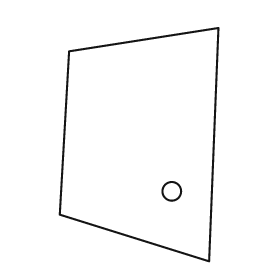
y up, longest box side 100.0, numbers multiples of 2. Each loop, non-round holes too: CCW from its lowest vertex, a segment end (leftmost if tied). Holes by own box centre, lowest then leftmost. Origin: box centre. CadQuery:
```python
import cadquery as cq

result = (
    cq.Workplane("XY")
    .moveTo(30.0, -50.0)
    .lineTo(34.0, 50.0)
    .lineTo(-30.0, 40.0)
    .lineTo(-34.0, -30.0)
    .close()
    .moveTo(14.0, -20.0)
    .circle(4.0)
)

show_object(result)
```